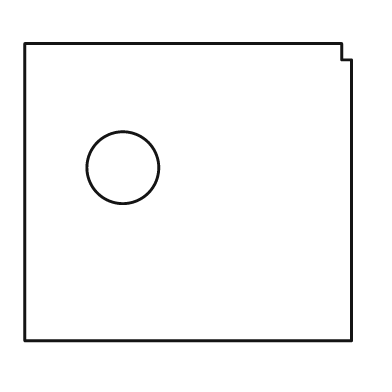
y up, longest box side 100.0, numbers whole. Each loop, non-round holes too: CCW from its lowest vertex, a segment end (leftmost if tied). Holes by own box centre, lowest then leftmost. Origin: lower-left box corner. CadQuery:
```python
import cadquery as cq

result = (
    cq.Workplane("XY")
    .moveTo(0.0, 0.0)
    .lineTo(100.0, 0.0)
    .lineTo(100.0, 86.0)
    .lineTo(97.0, 86.0)
    .lineTo(97.0, 91.0)
    .lineTo(0.0, 91.0)
    .close()
    .moveTo(30.0, 53.0)
    .circle(11.0)
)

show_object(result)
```